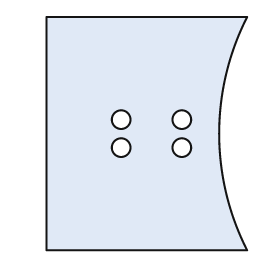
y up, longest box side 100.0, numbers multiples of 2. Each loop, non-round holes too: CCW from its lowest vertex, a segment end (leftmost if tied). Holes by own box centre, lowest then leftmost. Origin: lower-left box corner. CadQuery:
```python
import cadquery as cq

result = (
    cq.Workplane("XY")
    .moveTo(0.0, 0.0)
    .lineTo(86.0, 0.0)
    .threePointArc((74.0, 50.0), (86.0, 100.0))
    .lineTo(0.0, 100.0)
    .close()
    .moveTo(32.0, 44.0)
    .circle(4.0)
    .moveTo(58.0, 44.0)
    .circle(4.0)
    .moveTo(32.0, 56.0)
    .circle(4.0)
    .moveTo(58.0, 56.0)
    .circle(4.0)
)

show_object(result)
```